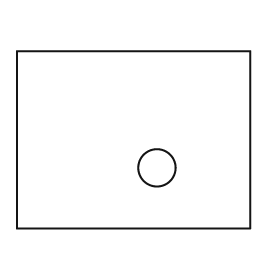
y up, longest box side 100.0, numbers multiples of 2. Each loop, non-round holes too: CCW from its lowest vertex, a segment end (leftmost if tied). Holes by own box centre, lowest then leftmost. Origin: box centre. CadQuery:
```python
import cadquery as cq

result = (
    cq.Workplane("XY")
    .moveTo(-50.0, -38.0)
    .lineTo(50.0, -38.0)
    .lineTo(50.0, 38.0)
    .lineTo(-50.0, 38.0)
    .close()
    .moveTo(10.0, -12.0)
    .circle(8.0)
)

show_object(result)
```